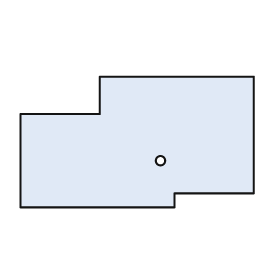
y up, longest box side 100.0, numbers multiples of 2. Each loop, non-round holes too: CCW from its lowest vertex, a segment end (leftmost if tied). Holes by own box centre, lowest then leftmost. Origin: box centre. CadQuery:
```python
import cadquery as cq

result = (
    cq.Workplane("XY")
    .moveTo(-50.0, -28.0)
    .lineTo(16.0, -28.0)
    .lineTo(16.0, -22.0)
    .lineTo(50.0, -22.0)
    .lineTo(50.0, 28.0)
    .lineTo(-16.0, 28.0)
    .lineTo(-16.0, 12.0)
    .lineTo(-50.0, 12.0)
    .close()
    .moveTo(10.0, -8.0)
    .circle(2.0)
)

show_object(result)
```